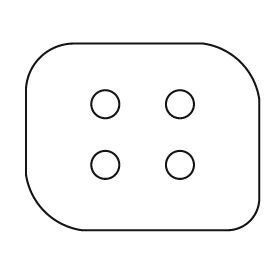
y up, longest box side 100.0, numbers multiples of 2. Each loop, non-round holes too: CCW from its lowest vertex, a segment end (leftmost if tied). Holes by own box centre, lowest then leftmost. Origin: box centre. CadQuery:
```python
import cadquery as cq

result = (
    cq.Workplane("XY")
    .moveTo(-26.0, -40.0)
    .lineTo(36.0, -40.0)
    .threePointArc((46.0, -36.0), (50.0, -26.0))
    .lineTo(50.0, 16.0)
    .threePointArc((42.0, 32.0), (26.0, 40.0))
    .lineTo(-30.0, 40.0)
    .threePointArc((-44.0, 34.0), (-50.0, 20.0))
    .lineTo(-50.0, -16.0)
    .threePointArc((-42.0, -32.0), (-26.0, -40.0))
    .close()
    .moveTo(-16.0, -12.0)
    .circle(6.0)
    .moveTo(16.0, -12.0)
    .circle(6.0)
    .moveTo(-16.0, 14.0)
    .circle(6.0)
    .moveTo(16.0, 14.0)
    .circle(6.0)
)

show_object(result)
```